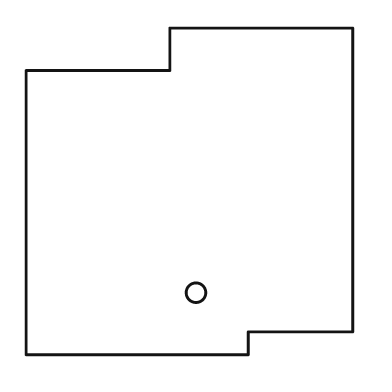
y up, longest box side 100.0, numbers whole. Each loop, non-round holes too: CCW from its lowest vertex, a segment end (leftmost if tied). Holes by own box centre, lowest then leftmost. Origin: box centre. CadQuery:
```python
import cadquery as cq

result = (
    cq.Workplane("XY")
    .moveTo(-50.0, -50.0)
    .lineTo(18.0, -50.0)
    .lineTo(18.0, -43.0)
    .lineTo(50.0, -43.0)
    .lineTo(50.0, 50.0)
    .lineTo(-6.0, 50.0)
    .lineTo(-6.0, 37.0)
    .lineTo(-50.0, 37.0)
    .close()
    .moveTo(2.0, -31.0)
    .circle(3.0)
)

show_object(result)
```